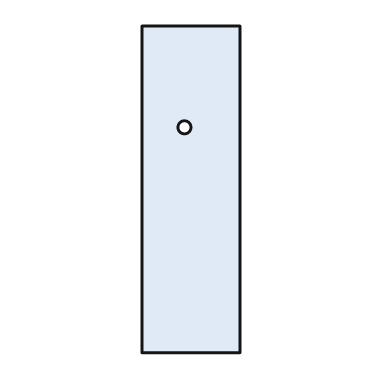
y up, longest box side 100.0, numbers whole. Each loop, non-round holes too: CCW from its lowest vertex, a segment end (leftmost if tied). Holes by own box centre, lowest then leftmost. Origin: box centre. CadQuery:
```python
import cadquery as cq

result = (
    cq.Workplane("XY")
    .moveTo(-15.0, -50.0)
    .lineTo(15.0, -50.0)
    .lineTo(15.0, 50.0)
    .lineTo(-15.0, 50.0)
    .close()
    .moveTo(-2.0, 19.0)
    .circle(2.0)
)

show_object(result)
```